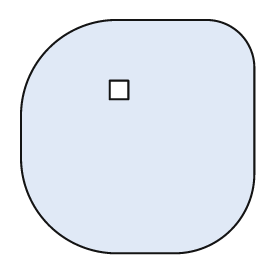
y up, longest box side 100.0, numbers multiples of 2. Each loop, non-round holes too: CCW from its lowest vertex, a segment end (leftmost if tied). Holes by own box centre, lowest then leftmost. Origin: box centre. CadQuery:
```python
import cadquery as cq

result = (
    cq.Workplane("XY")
    .moveTo(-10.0, -50.0)
    .lineTo(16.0, -50.0)
    .threePointArc((40.0, -40.0), (50.0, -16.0))
    .lineTo(50.0, 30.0)
    .threePointArc((44.0, 44.0), (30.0, 50.0))
    .lineTo(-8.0, 50.0)
    .threePointArc((-38.0, 38.0), (-50.0, 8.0))
    .lineTo(-50.0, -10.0)
    .threePointArc((-38.0, -38.0), (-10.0, -50.0))
    .close()
    .moveTo(-12.0, 16.0)
    .lineTo(-4.0, 16.0)
    .lineTo(-4.0, 24.0)
    .lineTo(-12.0, 24.0)
    .close()
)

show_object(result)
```